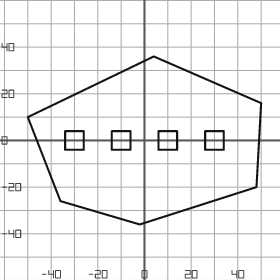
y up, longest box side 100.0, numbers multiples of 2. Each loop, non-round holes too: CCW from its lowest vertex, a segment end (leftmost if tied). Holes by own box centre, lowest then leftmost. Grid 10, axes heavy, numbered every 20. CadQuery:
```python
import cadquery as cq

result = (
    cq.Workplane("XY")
    .moveTo(-2.0, -36.0)
    .lineTo(48.0, -20.0)
    .lineTo(50.0, 16.0)
    .lineTo(4.0, 36.0)
    .lineTo(-50.0, 10.0)
    .lineTo(-36.0, -26.0)
    .close()
    .moveTo(-34.0, -4.0)
    .lineTo(-26.0, -4.0)
    .lineTo(-26.0, 4.0)
    .lineTo(-34.0, 4.0)
    .close()
    .moveTo(-14.0, -4.0)
    .lineTo(-6.0, -4.0)
    .lineTo(-6.0, 4.0)
    .lineTo(-14.0, 4.0)
    .close()
    .moveTo(6.0, -4.0)
    .lineTo(14.0, -4.0)
    .lineTo(14.0, 4.0)
    .lineTo(6.0, 4.0)
    .close()
    .moveTo(26.0, -4.0)
    .lineTo(34.0, -4.0)
    .lineTo(34.0, 4.0)
    .lineTo(26.0, 4.0)
    .close()
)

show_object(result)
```